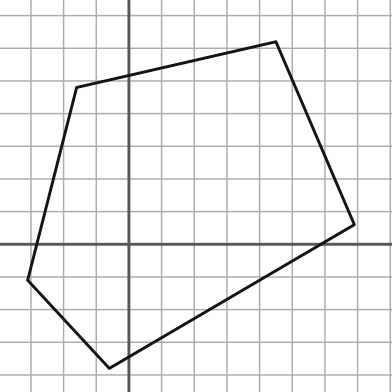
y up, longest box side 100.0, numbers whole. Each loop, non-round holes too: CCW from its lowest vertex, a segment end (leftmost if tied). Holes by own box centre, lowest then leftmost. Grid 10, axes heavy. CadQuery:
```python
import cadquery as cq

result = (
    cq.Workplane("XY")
    .moveTo(-6.0, -38.0)
    .lineTo(69.0, 6.0)
    .lineTo(45.0, 62.0)
    .lineTo(-16.0, 48.0)
    .lineTo(-31.0, -11.0)
    .close()
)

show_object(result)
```